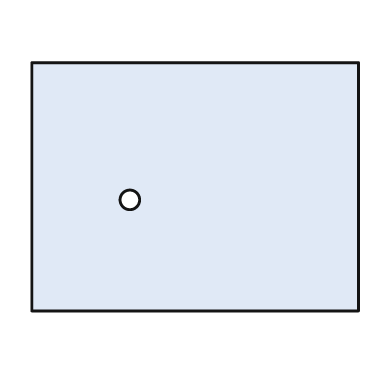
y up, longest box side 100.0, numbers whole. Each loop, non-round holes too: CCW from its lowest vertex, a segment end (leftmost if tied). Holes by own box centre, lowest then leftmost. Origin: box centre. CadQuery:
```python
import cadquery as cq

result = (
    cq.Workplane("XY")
    .moveTo(-50.0, -38.0)
    .lineTo(50.0, -38.0)
    .lineTo(50.0, 38.0)
    .lineTo(-50.0, 38.0)
    .close()
    .moveTo(-20.0, -4.0)
    .circle(3.0)
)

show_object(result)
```